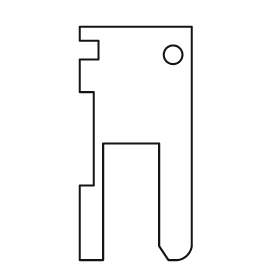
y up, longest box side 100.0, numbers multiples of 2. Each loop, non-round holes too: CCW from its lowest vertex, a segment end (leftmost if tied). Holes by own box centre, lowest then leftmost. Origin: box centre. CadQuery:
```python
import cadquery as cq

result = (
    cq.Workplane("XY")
    .moveTo(-24.0, -50.0)
    .lineTo(-14.0, -50.0)
    .lineTo(-14.0, 0.0)
    .lineTo(10.0, 0.0)
    .lineTo(10.0, -44.0)
    .lineTo(14.0, -50.0)
    .lineTo(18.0, -50.0)
    .threePointArc((22.0, -48.0), (24.0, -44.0))
    .lineTo(24.0, 50.0)
    .lineTo(-24.0, 50.0)
    .lineTo(-24.0, 44.0)
    .lineTo(-16.0, 44.0)
    .lineTo(-16.0, 36.0)
    .lineTo(-24.0, 36.0)
    .lineTo(-24.0, 22.0)
    .lineTo(-18.0, 22.0)
    .lineTo(-18.0, -18.0)
    .lineTo(-24.0, -18.0)
    .close()
    .moveTo(16.0, 38.0)
    .circle(4.0)
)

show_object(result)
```